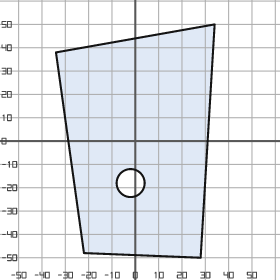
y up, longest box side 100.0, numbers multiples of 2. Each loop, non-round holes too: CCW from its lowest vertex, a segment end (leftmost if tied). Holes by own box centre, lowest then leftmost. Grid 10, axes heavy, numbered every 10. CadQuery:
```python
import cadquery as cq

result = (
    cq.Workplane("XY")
    .moveTo(28.0, -50.0)
    .lineTo(34.0, 50.0)
    .lineTo(-34.0, 38.0)
    .lineTo(-22.0, -48.0)
    .close()
    .moveTo(-2.0, -18.0)
    .circle(6.0)
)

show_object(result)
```